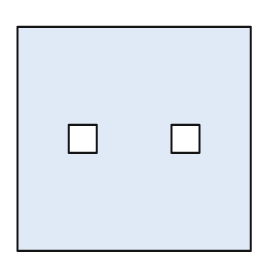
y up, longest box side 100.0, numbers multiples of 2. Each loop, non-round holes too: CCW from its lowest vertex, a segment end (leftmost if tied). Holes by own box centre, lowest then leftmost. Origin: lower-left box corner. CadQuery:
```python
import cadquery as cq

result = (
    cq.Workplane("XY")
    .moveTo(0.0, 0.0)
    .lineTo(100.0, 0.0)
    .lineTo(100.0, 96.0)
    .lineTo(0.0, 96.0)
    .close()
    .moveTo(22.0, 42.0)
    .lineTo(34.0, 42.0)
    .lineTo(34.0, 54.0)
    .lineTo(22.0, 54.0)
    .close()
    .moveTo(66.0, 42.0)
    .lineTo(78.0, 42.0)
    .lineTo(78.0, 54.0)
    .lineTo(66.0, 54.0)
    .close()
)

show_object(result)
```